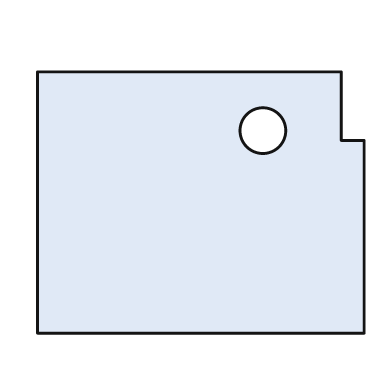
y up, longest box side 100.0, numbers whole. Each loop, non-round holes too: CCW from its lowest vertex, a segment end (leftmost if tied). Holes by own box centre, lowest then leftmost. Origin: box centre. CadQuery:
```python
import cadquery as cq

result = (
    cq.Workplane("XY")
    .moveTo(-50.0, -40.0)
    .lineTo(50.0, -40.0)
    .lineTo(50.0, 19.0)
    .lineTo(43.0, 19.0)
    .lineTo(43.0, 40.0)
    .lineTo(-50.0, 40.0)
    .close()
    .moveTo(19.0, 22.0)
    .circle(7.0)
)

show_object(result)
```